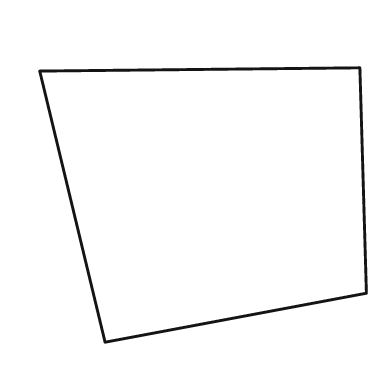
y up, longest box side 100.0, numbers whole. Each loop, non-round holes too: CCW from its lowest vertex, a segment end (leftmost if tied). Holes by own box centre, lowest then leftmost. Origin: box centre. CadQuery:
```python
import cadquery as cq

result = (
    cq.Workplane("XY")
    .moveTo(-30.0, -42.0)
    .lineTo(50.0, -27.0)
    .lineTo(48.0, 42.0)
    .lineTo(-50.0, 41.0)
    .close()
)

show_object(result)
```